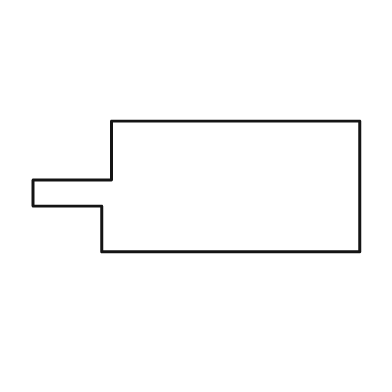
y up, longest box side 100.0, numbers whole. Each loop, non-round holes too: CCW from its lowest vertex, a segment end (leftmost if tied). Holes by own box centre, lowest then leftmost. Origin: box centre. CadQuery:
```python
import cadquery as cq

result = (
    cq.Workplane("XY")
    .moveTo(-29.0, -20.0)
    .lineTo(50.0, -20.0)
    .lineTo(50.0, 20.0)
    .lineTo(-26.0, 20.0)
    .lineTo(-26.0, 2.0)
    .lineTo(-50.0, 2.0)
    .lineTo(-50.0, -6.0)
    .lineTo(-29.0, -6.0)
    .close()
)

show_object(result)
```